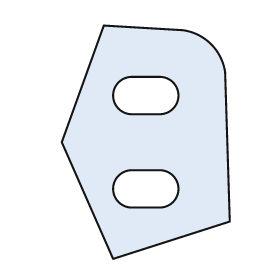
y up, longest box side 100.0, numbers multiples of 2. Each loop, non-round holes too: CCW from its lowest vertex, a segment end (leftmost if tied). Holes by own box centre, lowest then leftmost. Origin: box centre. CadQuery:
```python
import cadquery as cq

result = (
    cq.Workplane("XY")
    .moveTo(-14.0, -50.0)
    .lineTo(36.0, -34.0)
    .lineTo(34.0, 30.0)
    .threePointArc((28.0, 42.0), (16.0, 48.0))
    .lineTo(-18.0, 50.0)
    .lineTo(-36.0, 0.0)
    .close()
    .moveTo(-6.0, -28.0)
    .lineTo(6.0, -28.0)
    .threePointArc((14.0, -20.0), (6.0, -12.0))
    .lineTo(-6.0, -12.0)
    .threePointArc((-14.0, -20.0), (-6.0, -28.0))
    .close()
    .moveTo(-6.0, 12.0)
    .lineTo(6.0, 12.0)
    .threePointArc((14.0, 20.0), (6.0, 28.0))
    .lineTo(-6.0, 28.0)
    .threePointArc((-14.0, 20.0), (-6.0, 12.0))
    .close()
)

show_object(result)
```